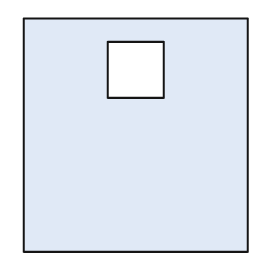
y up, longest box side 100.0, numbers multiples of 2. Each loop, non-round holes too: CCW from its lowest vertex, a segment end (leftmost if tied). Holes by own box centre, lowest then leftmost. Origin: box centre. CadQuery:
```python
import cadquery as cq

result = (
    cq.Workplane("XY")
    .moveTo(-48.0, -50.0)
    .lineTo(48.0, -50.0)
    .lineTo(48.0, 50.0)
    .lineTo(-48.0, 50.0)
    .close()
    .moveTo(-12.0, 16.0)
    .lineTo(12.0, 16.0)
    .lineTo(12.0, 40.0)
    .lineTo(-12.0, 40.0)
    .close()
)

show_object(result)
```